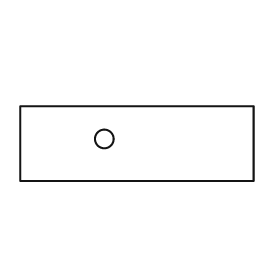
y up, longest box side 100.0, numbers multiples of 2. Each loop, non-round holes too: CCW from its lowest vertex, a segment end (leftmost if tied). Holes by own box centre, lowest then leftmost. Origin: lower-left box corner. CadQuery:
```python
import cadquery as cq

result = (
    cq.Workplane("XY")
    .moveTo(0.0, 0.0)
    .lineTo(100.0, 0.0)
    .lineTo(100.0, 32.0)
    .lineTo(0.0, 32.0)
    .close()
    .moveTo(36.0, 18.0)
    .circle(4.0)
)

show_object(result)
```